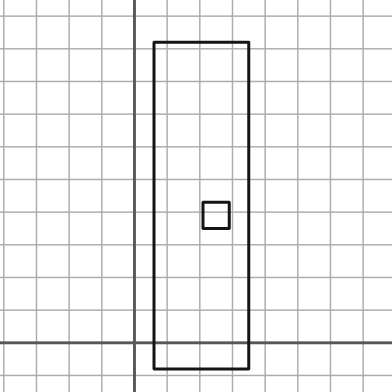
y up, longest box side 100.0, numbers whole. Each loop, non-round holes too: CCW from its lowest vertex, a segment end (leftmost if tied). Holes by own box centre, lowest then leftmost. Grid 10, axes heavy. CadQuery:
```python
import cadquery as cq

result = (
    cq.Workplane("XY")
    .moveTo(6.0, -8.0)
    .lineTo(35.0, -8.0)
    .lineTo(35.0, 92.0)
    .lineTo(6.0, 92.0)
    .close()
    .moveTo(21.0, 35.0)
    .lineTo(29.0, 35.0)
    .lineTo(29.0, 43.0)
    .lineTo(21.0, 43.0)
    .close()
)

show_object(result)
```